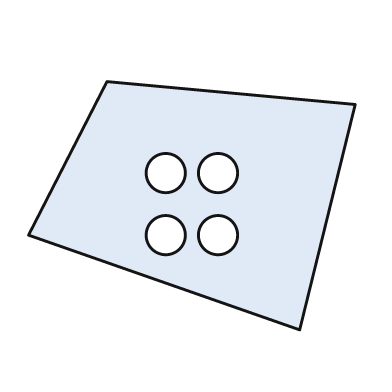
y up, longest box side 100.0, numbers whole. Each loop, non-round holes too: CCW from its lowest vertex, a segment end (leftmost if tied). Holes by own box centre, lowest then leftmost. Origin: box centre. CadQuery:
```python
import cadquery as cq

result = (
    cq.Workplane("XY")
    .moveTo(33.0, -38.0)
    .lineTo(50.0, 31.0)
    .lineTo(-26.0, 38.0)
    .lineTo(-50.0, -9.0)
    .close()
    .moveTo(-8.0, -9.0)
    .circle(6.0)
    .moveTo(8.0, -9.0)
    .circle(6.0)
    .moveTo(-8.0, 10.0)
    .circle(6.0)
    .moveTo(8.0, 10.0)
    .circle(6.0)
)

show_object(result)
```